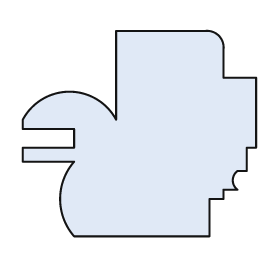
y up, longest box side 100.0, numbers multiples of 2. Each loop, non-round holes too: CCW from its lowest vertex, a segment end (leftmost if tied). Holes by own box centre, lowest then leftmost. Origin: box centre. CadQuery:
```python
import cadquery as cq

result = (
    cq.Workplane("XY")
    .moveTo(-28.0, -44.0)
    .lineTo(30.0, -44.0)
    .lineTo(30.0, -28.0)
    .lineTo(36.0, -28.0)
    .lineTo(36.0, -24.0)
    .lineTo(42.0, -24.0)
    .threePointArc((40.0, -20.0), (42.0, -16.0))
    .lineTo(46.0, -16.0)
    .lineTo(46.0, -6.0)
    .lineTo(50.0, -6.0)
    .lineTo(50.0, 24.0)
    .lineTo(36.0, 24.0)
    .lineTo(36.0, 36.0)
    .threePointArc((34.0, 42.0), (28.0, 44.0))
    .lineTo(-10.0, 44.0)
    .lineTo(-10.0, 6.0)
    .threePointArc((-30.0, 18.0), (-50.0, 6.0))
    .lineTo(-50.0, 2.0)
    .lineTo(-28.0, 2.0)
    .lineTo(-28.0, -6.0)
    .lineTo(-50.0, -6.0)
    .lineTo(-50.0, -12.0)
    .lineTo(-28.0, -12.0)
    .threePointArc((-34.0, -28.0), (-28.0, -44.0))
    .close()
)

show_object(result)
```